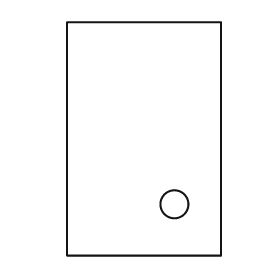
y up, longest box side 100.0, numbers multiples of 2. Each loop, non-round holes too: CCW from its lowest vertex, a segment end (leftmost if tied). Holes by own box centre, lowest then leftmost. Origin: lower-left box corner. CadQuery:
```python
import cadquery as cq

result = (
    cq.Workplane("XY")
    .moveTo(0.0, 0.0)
    .lineTo(66.0, 0.0)
    .lineTo(66.0, 100.0)
    .lineTo(0.0, 100.0)
    .close()
    .moveTo(46.0, 22.0)
    .circle(6.0)
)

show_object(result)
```